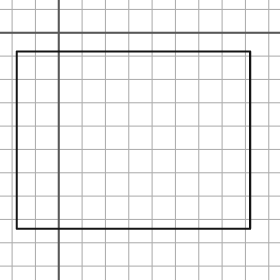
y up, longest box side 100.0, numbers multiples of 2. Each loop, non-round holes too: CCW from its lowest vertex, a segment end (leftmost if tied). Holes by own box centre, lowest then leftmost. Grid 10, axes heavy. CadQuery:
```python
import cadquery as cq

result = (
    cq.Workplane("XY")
    .moveTo(-18.0, -84.0)
    .lineTo(82.0, -84.0)
    .lineTo(82.0, -8.0)
    .lineTo(-18.0, -8.0)
    .close()
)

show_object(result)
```